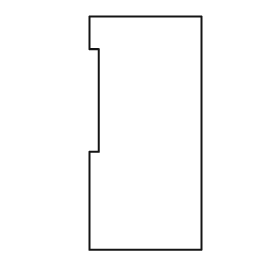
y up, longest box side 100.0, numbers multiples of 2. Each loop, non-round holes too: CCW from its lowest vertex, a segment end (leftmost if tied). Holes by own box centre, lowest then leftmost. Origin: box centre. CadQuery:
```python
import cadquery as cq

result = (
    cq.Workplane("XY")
    .moveTo(-24.0, -50.0)
    .lineTo(24.0, -50.0)
    .lineTo(24.0, 50.0)
    .lineTo(-24.0, 50.0)
    .lineTo(-24.0, 36.0)
    .lineTo(-20.0, 36.0)
    .lineTo(-20.0, -8.0)
    .lineTo(-24.0, -8.0)
    .close()
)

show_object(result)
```